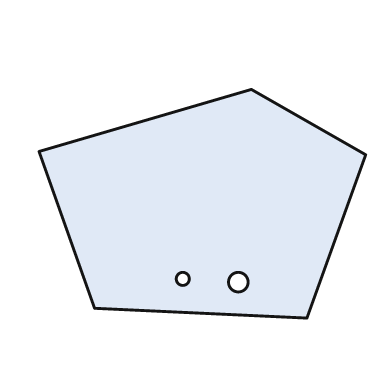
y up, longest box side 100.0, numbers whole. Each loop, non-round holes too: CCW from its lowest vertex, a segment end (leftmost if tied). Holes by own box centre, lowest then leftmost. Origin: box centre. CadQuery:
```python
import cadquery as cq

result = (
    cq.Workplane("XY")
    .moveTo(32.0, -35.0)
    .lineTo(50.0, 15.0)
    .lineTo(15.0, 35.0)
    .lineTo(-50.0, 16.0)
    .lineTo(-33.0, -32.0)
    .close()
    .moveTo(11.0, -24.0)
    .circle(3.0)
    .moveTo(-6.0, -23.0)
    .circle(2.0)
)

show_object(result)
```